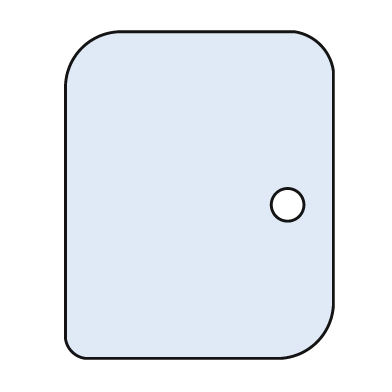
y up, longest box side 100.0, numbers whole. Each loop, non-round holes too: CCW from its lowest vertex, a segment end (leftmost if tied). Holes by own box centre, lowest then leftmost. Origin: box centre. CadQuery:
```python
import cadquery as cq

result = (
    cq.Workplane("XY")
    .moveTo(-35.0, -50.0)
    .lineTo(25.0, -50.0)
    .threePointArc((36.0, -45.0), (41.0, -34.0))
    .lineTo(41.0, 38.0)
    .threePointArc((37.0, 46.0), (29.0, 50.0))
    .lineTo(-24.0, 50.0)
    .threePointArc((-36.0, 45.0), (-41.0, 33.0))
    .lineTo(-41.0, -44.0)
    .threePointArc((-39.0, -48.0), (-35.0, -50.0))
    .close()
    .moveTo(27.0, -3.0)
    .circle(5.0)
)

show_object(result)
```